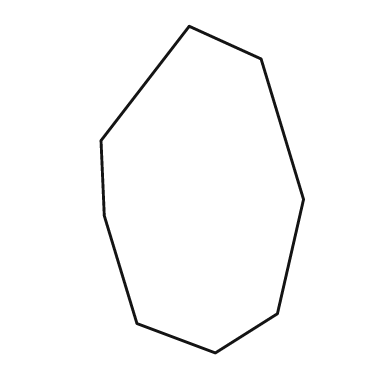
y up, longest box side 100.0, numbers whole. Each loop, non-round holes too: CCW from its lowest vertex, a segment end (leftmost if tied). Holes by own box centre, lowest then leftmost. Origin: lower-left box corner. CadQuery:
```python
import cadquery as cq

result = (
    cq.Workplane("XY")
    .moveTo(35.0, 0.0)
    .lineTo(54.0, 12.0)
    .lineTo(62.0, 47.0)
    .lineTo(49.0, 90.0)
    .lineTo(27.0, 100.0)
    .lineTo(0.0, 65.0)
    .lineTo(1.0, 42.0)
    .lineTo(11.0, 9.0)
    .close()
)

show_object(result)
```